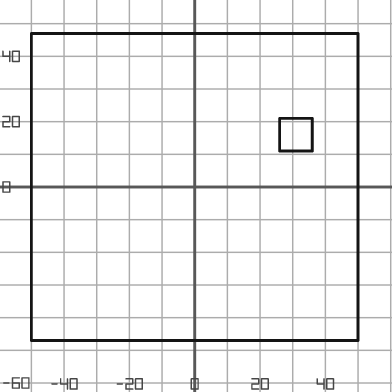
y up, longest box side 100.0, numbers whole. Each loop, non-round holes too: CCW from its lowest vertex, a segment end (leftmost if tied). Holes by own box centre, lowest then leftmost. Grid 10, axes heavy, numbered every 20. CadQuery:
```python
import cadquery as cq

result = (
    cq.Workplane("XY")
    .moveTo(-50.0, -47.0)
    .lineTo(50.0, -47.0)
    .lineTo(50.0, 47.0)
    .lineTo(-50.0, 47.0)
    .close()
    .moveTo(26.0, 11.0)
    .lineTo(36.0, 11.0)
    .lineTo(36.0, 21.0)
    .lineTo(26.0, 21.0)
    .close()
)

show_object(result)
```